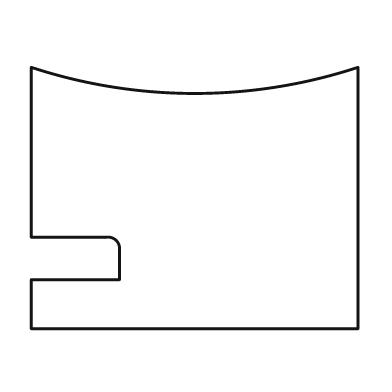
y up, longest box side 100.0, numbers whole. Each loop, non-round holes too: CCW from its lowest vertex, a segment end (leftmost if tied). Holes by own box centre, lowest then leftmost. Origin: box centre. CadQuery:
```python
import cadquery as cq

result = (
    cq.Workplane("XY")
    .moveTo(-50.0, -40.0)
    .lineTo(50.0, -40.0)
    .lineTo(50.0, 40.0)
    .threePointArc((0.0, 32.0), (-50.0, 40.0))
    .lineTo(-50.0, -12.0)
    .lineTo(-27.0, -12.0)
    .threePointArc((-24.0, -13.0), (-23.0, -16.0))
    .lineTo(-23.0, -25.0)
    .lineTo(-50.0, -25.0)
    .close()
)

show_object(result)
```